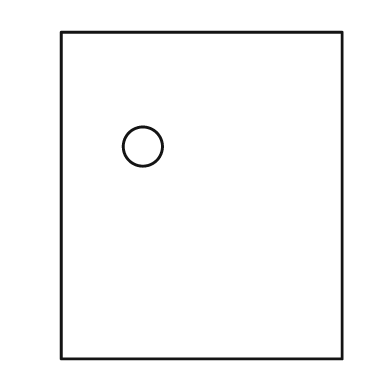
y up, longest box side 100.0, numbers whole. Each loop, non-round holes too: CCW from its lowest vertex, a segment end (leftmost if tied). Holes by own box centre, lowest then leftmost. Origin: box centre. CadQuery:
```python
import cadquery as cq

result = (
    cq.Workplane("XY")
    .moveTo(-43.0, -50.0)
    .lineTo(43.0, -50.0)
    .lineTo(43.0, 50.0)
    .lineTo(-43.0, 50.0)
    .close()
    .moveTo(-18.0, 15.0)
    .circle(6.0)
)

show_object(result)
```